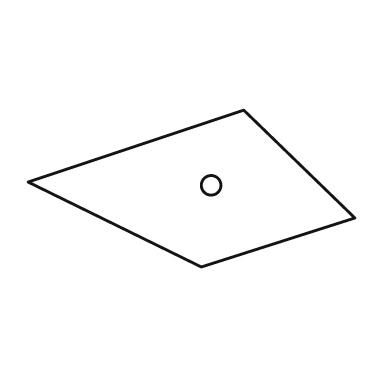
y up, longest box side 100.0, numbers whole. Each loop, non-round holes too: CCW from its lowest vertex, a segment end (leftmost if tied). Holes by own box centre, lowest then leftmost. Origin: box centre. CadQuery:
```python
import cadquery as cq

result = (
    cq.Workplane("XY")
    .moveTo(3.0, -24.0)
    .lineTo(50.0, -9.0)
    .lineTo(16.0, 24.0)
    .lineTo(-50.0, 2.0)
    .close()
    .moveTo(6.0, 1.0)
    .circle(3.0)
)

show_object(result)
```